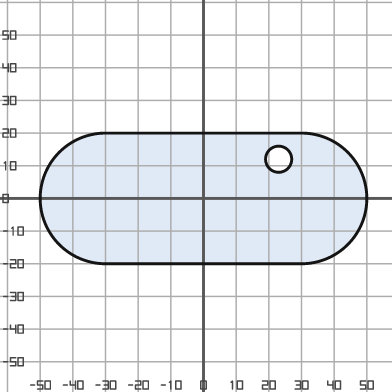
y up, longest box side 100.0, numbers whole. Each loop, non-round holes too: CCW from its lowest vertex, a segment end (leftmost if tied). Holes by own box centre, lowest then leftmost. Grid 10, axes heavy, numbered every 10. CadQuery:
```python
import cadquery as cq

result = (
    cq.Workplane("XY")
    .moveTo(-30.0, -20.0)
    .lineTo(30.0, -20.0)
    .threePointArc((50.0, 0.0), (30.0, 20.0))
    .lineTo(-30.0, 20.0)
    .threePointArc((-50.0, 0.0), (-30.0, -20.0))
    .close()
    .moveTo(23.0, 12.0)
    .circle(4.0)
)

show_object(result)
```